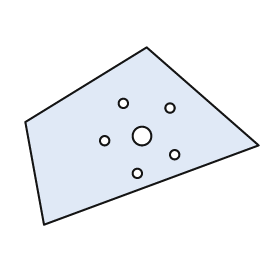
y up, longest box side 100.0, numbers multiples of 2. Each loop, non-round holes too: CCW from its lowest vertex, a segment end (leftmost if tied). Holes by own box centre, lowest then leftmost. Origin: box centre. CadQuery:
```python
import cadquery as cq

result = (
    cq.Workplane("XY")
    .moveTo(-42.0, -38.0)
    .lineTo(50.0, -4.0)
    .lineTo(2.0, 38.0)
    .lineTo(-50.0, 6.0)
    .close()
    .moveTo(-2.0, -16.0)
    .circle(2.0)
    .moveTo(14.0, -8.0)
    .circle(2.0)
    .moveTo(-16.0, -2.0)
    .circle(2.0)
    .moveTo(0.0, 0.0)
    .circle(4.0)
    .moveTo(12.0, 12.0)
    .circle(2.0)
    .moveTo(-8.0, 14.0)
    .circle(2.0)
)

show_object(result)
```